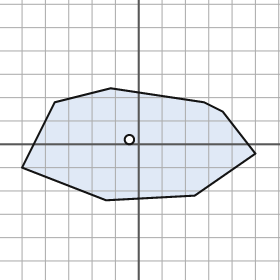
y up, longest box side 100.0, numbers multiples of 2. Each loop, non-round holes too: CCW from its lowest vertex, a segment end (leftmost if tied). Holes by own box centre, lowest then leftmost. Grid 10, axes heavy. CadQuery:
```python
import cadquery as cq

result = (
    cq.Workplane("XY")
    .moveTo(-14.0, -24.0)
    .lineTo(24.0, -22.0)
    .lineTo(50.0, -4.0)
    .lineTo(36.0, 14.0)
    .lineTo(28.0, 18.0)
    .lineTo(-12.0, 24.0)
    .lineTo(-36.0, 18.0)
    .lineTo(-50.0, -10.0)
    .close()
    .moveTo(-4.0, 2.0)
    .circle(2.0)
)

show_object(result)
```